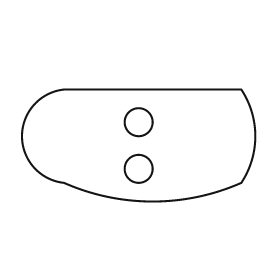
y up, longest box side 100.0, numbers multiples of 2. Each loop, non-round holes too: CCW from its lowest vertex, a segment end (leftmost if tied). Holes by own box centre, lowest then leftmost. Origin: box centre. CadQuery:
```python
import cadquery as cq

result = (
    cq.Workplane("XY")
    .moveTo(-32.0, -16.0)
    .threePointArc((6.0, -24.0), (44.0, -16.0))
    .threePointArc((50.0, 4.0), (44.0, 24.0))
    .lineTo(-32.0, 24.0)
    .threePointArc((-50.0, 4.0), (-32.0, -16.0))
    .close()
    .moveTo(0.0, -10.0)
    .circle(6.0)
    .moveTo(0.0, 10.0)
    .circle(6.0)
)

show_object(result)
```